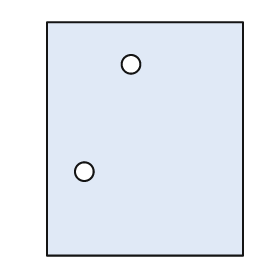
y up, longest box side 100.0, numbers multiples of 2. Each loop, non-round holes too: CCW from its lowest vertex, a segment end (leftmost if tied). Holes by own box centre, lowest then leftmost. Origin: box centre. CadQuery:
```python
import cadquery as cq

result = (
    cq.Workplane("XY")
    .moveTo(-42.0, -50.0)
    .lineTo(42.0, -50.0)
    .lineTo(42.0, 50.0)
    .lineTo(-42.0, 50.0)
    .close()
    .moveTo(-26.0, -14.0)
    .circle(4.0)
    .moveTo(-6.0, 32.0)
    .circle(4.0)
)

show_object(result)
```